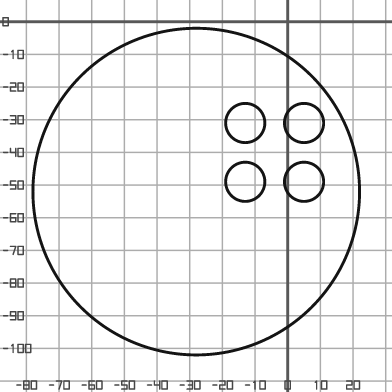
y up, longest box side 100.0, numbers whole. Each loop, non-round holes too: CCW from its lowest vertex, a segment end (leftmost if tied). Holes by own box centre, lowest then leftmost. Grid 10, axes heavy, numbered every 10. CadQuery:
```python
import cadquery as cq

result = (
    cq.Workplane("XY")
    .moveTo(-28.0, -52.0)
    .circle(50.0)
    .moveTo(-13.0, -49.0)
    .circle(6.0)
    .moveTo(5.0, -49.0)
    .circle(6.0)
    .moveTo(-13.0, -31.0)
    .circle(6.0)
    .moveTo(5.0, -31.0)
    .circle(6.0)
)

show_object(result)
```